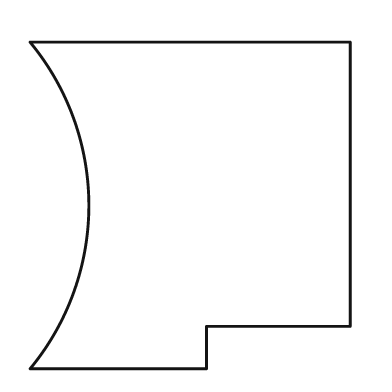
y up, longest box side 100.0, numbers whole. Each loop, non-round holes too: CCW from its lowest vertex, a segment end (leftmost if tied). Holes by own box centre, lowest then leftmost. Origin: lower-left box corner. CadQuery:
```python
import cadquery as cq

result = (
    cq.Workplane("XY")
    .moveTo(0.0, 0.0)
    .lineTo(54.0, 0.0)
    .lineTo(54.0, 13.0)
    .lineTo(98.0, 13.0)
    .lineTo(98.0, 100.0)
    .lineTo(0.0, 100.0)
    .threePointArc((18.0, 50.0), (0.0, 0.0))
    .close()
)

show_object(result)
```